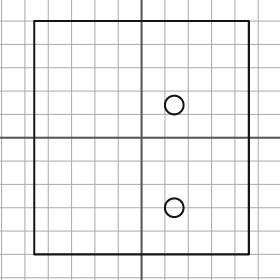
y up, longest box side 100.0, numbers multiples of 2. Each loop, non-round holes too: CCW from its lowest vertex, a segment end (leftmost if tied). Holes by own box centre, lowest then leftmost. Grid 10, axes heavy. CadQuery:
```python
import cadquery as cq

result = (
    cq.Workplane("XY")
    .moveTo(-46.0, -50.0)
    .lineTo(46.0, -50.0)
    .lineTo(46.0, 50.0)
    .lineTo(-46.0, 50.0)
    .close()
    .moveTo(14.0, -30.0)
    .circle(4.0)
    .moveTo(14.0, 14.0)
    .circle(4.0)
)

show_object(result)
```